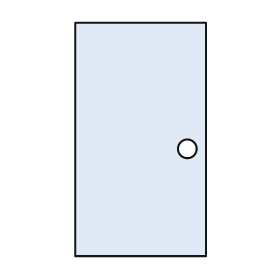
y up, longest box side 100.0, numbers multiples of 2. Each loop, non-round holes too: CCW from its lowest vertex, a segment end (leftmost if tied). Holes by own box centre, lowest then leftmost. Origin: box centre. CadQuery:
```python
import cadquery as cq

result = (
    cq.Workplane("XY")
    .moveTo(-28.0, -50.0)
    .lineTo(28.0, -50.0)
    .lineTo(28.0, 50.0)
    .lineTo(-28.0, 50.0)
    .close()
    .moveTo(20.0, -4.0)
    .circle(4.0)
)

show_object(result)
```